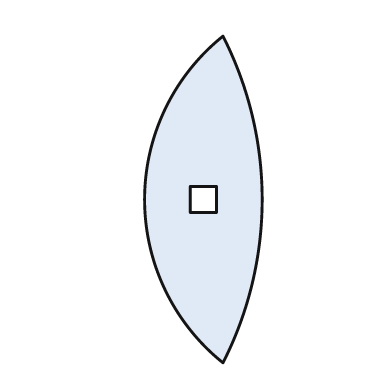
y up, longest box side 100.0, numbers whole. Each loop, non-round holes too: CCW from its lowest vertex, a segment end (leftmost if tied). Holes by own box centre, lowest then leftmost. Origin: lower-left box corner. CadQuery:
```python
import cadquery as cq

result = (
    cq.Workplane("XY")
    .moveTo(24.0, 0.0)
    .threePointArc((36.0, 50.0), (24.0, 100.0))
    .threePointArc((0.0, 50.0), (24.0, 0.0))
    .close()
    .moveTo(14.0, 46.0)
    .lineTo(22.0, 46.0)
    .lineTo(22.0, 54.0)
    .lineTo(14.0, 54.0)
    .close()
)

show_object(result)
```